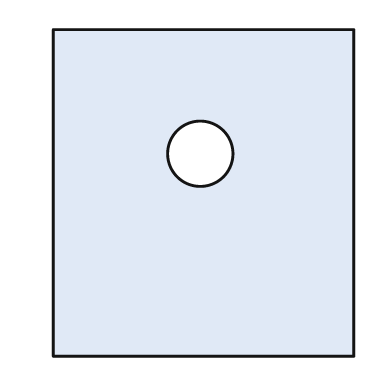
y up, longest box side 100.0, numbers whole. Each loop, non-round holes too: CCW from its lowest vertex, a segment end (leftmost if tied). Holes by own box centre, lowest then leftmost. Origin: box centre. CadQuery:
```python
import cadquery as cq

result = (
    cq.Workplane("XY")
    .moveTo(-46.0, -50.0)
    .lineTo(46.0, -50.0)
    .lineTo(46.0, 50.0)
    .lineTo(-46.0, 50.0)
    .close()
    .moveTo(-1.0, 12.0)
    .circle(10.0)
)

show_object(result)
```